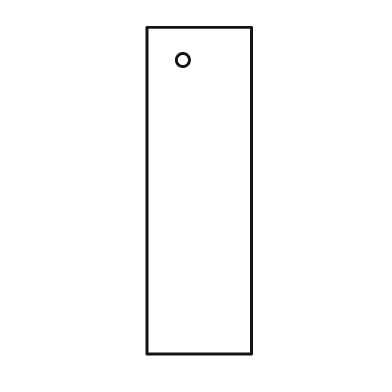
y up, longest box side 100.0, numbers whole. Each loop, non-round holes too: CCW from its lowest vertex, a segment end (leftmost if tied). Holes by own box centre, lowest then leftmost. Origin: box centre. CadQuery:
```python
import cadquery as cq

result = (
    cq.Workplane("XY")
    .moveTo(-16.0, -50.0)
    .lineTo(16.0, -50.0)
    .lineTo(16.0, 50.0)
    .lineTo(-16.0, 50.0)
    .close()
    .moveTo(-5.0, 40.0)
    .circle(2.0)
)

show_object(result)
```